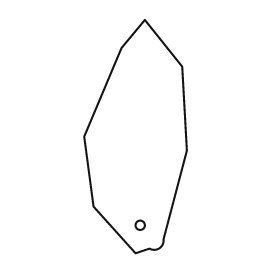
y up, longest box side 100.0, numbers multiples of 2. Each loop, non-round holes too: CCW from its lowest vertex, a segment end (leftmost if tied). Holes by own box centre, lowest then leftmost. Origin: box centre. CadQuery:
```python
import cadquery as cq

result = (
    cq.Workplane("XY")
    .moveTo(0.0, -50.0)
    .lineTo(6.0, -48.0)
    .threePointArc((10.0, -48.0), (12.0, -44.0))
    .lineTo(22.0, -6.0)
    .lineTo(20.0, 30.0)
    .lineTo(4.0, 50.0)
    .lineTo(-6.0, 38.0)
    .lineTo(-22.0, 0.0)
    .lineTo(-18.0, -30.0)
    .close()
    .moveTo(2.0, -38.0)
    .circle(2.0)
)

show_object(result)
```